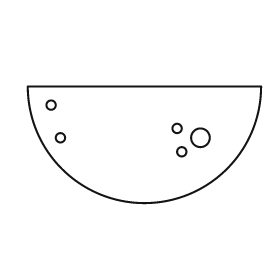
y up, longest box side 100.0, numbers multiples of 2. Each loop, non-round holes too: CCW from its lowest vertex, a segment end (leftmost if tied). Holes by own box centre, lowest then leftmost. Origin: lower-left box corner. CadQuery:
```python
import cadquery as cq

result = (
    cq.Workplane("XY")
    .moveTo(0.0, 50.0)
    .threePointArc((50.0, 0.0), (100.0, 50.0))
    .close()
    .moveTo(66.0, 22.0)
    .circle(2.0)
    .moveTo(14.0, 28.0)
    .circle(2.0)
    .moveTo(74.0, 28.0)
    .circle(4.0)
    .moveTo(64.0, 32.0)
    .circle(2.0)
    .moveTo(10.0, 42.0)
    .circle(2.0)
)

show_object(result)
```